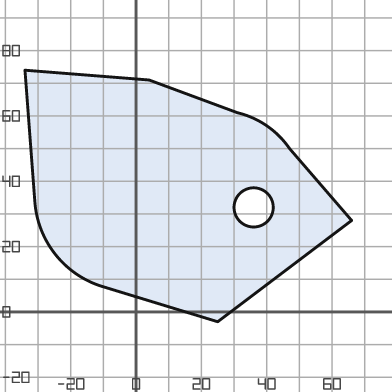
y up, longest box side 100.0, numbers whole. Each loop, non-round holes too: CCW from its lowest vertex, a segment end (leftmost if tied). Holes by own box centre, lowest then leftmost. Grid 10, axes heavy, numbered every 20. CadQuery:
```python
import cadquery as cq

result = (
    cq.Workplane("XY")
    .moveTo(25.0, -3.0)
    .lineTo(66.0, 28.0)
    .lineTo(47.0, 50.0)
    .threePointArc((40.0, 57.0), (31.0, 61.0))
    .lineTo(4.0, 71.0)
    .lineTo(-34.0, 74.0)
    .lineTo(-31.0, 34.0)
    .threePointArc((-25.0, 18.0), (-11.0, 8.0))
    .close()
    .moveTo(36.0, 32.0)
    .circle(6.0)
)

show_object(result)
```